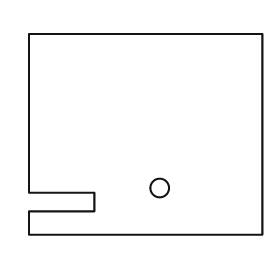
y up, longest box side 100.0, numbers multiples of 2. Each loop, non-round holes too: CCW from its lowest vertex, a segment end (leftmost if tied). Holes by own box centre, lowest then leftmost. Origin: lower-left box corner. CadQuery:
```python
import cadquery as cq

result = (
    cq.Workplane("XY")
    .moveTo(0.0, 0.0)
    .lineTo(100.0, 0.0)
    .lineTo(100.0, 86.0)
    .lineTo(0.0, 86.0)
    .lineTo(0.0, 18.0)
    .lineTo(28.0, 18.0)
    .lineTo(28.0, 10.0)
    .lineTo(0.0, 10.0)
    .close()
    .moveTo(56.0, 20.0)
    .circle(4.0)
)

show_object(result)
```